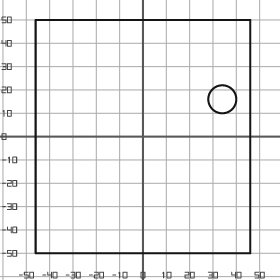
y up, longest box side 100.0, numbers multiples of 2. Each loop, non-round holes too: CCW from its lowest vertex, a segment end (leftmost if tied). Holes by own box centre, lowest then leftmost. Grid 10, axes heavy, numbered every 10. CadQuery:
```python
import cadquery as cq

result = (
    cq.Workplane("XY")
    .moveTo(-46.0, -50.0)
    .lineTo(46.0, -50.0)
    .lineTo(46.0, 50.0)
    .lineTo(-46.0, 50.0)
    .close()
    .moveTo(34.0, 16.0)
    .circle(6.0)
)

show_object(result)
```